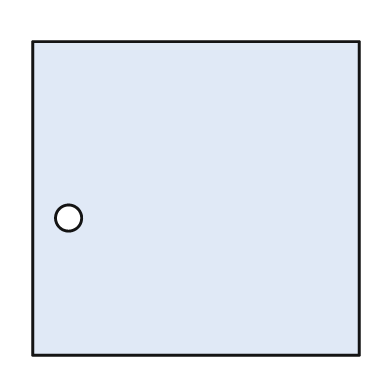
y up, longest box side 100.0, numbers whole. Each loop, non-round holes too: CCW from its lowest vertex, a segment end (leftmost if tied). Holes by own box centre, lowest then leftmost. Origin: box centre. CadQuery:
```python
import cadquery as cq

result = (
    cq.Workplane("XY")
    .moveTo(-50.0, -48.0)
    .lineTo(50.0, -48.0)
    .lineTo(50.0, 48.0)
    .lineTo(-50.0, 48.0)
    .close()
    .moveTo(-39.0, -6.0)
    .circle(4.0)
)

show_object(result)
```